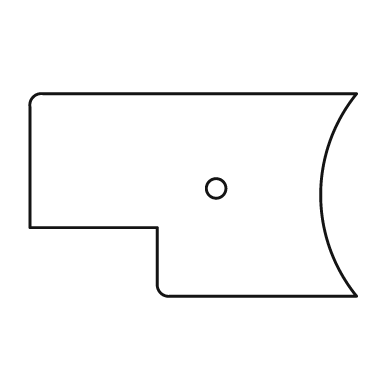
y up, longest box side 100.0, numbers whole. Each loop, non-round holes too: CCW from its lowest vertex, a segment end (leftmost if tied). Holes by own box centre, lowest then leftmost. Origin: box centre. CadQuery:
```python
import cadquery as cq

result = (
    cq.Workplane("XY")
    .moveTo(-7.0, -31.0)
    .lineTo(50.0, -31.0)
    .threePointArc((39.0, 0.0), (50.0, 31.0))
    .lineTo(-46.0, 31.0)
    .threePointArc((-49.0, 30.0), (-50.0, 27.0))
    .lineTo(-50.0, -10.0)
    .lineTo(-11.0, -10.0)
    .lineTo(-11.0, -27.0)
    .threePointArc((-10.0, -30.0), (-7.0, -31.0))
    .close()
    .moveTo(7.0, 2.0)
    .circle(3.0)
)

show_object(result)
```